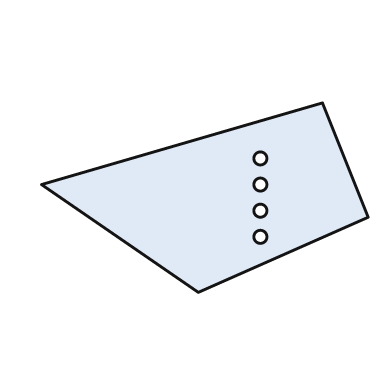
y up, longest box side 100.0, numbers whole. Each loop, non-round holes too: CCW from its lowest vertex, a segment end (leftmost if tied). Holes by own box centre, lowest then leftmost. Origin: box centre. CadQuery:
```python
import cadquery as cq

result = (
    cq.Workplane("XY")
    .moveTo(-2.0, -29.0)
    .lineTo(50.0, -6.0)
    .lineTo(36.0, 29.0)
    .lineTo(-50.0, 4.0)
    .close()
    .moveTo(17.0, -12.0)
    .circle(2.0)
    .moveTo(17.0, -4.0)
    .circle(2.0)
    .moveTo(17.0, 4.0)
    .circle(2.0)
    .moveTo(17.0, 12.0)
    .circle(2.0)
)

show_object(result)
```